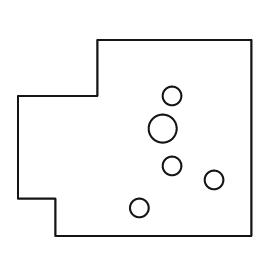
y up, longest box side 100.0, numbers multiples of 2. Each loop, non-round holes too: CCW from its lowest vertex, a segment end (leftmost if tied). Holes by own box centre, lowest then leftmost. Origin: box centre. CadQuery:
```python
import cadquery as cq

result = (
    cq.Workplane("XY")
    .moveTo(-34.0, -42.0)
    .lineTo(50.0, -42.0)
    .lineTo(50.0, 42.0)
    .lineTo(-16.0, 42.0)
    .lineTo(-16.0, 18.0)
    .lineTo(-50.0, 18.0)
    .lineTo(-50.0, -26.0)
    .lineTo(-34.0, -26.0)
    .close()
    .moveTo(2.0, -30.0)
    .circle(4.0)
    .moveTo(34.0, -18.0)
    .circle(4.0)
    .moveTo(16.0, -12.0)
    .circle(4.0)
    .moveTo(12.0, 4.0)
    .circle(6.0)
    .moveTo(16.0, 18.0)
    .circle(4.0)
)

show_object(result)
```